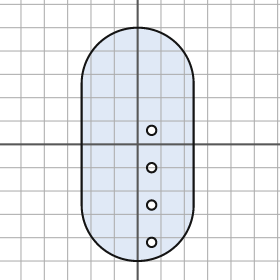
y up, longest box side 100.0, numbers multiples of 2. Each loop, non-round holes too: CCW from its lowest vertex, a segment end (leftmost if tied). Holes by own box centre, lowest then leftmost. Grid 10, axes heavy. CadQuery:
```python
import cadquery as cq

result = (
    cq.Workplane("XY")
    .moveTo(-24.0, -26.0)
    .threePointArc((0.0, -50.0), (24.0, -26.0))
    .lineTo(24.0, 26.0)
    .threePointArc((0.0, 50.0), (-24.0, 26.0))
    .close()
    .moveTo(6.0, -42.0)
    .circle(2.0)
    .moveTo(6.0, -26.0)
    .circle(2.0)
    .moveTo(6.0, -10.0)
    .circle(2.0)
    .moveTo(6.0, 6.0)
    .circle(2.0)
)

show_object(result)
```